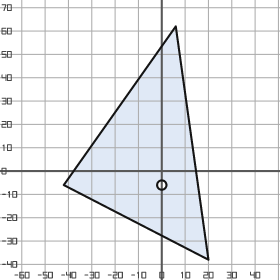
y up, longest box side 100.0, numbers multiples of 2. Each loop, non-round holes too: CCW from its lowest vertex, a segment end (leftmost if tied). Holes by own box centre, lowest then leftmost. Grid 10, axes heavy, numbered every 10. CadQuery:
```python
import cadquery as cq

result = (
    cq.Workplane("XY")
    .moveTo(20.0, -38.0)
    .lineTo(6.0, 62.0)
    .lineTo(-42.0, -6.0)
    .close()
    .moveTo(0.0, -6.0)
    .circle(2.0)
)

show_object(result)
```